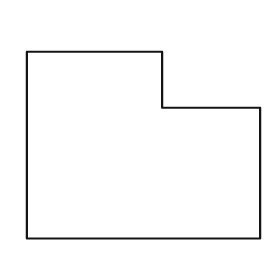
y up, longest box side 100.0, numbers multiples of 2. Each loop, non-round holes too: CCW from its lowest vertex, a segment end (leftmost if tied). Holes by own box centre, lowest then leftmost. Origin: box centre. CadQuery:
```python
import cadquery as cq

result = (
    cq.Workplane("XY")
    .moveTo(-50.0, -40.0)
    .lineTo(50.0, -40.0)
    .lineTo(50.0, 16.0)
    .lineTo(8.0, 16.0)
    .lineTo(8.0, 40.0)
    .lineTo(-50.0, 40.0)
    .close()
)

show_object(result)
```